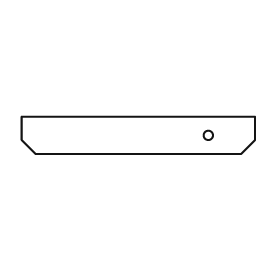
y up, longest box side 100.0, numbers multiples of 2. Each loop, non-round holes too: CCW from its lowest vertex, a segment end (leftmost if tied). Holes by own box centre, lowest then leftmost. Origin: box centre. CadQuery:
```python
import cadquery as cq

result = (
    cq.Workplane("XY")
    .moveTo(-44.0, -8.0)
    .lineTo(44.0, -8.0)
    .lineTo(50.0, -2.0)
    .lineTo(50.0, 8.0)
    .lineTo(-50.0, 8.0)
    .lineTo(-50.0, -2.0)
    .close()
    .moveTo(30.0, 0.0)
    .circle(2.0)
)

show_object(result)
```